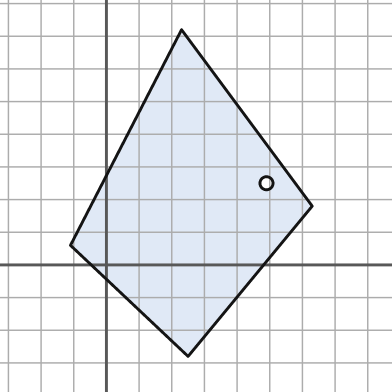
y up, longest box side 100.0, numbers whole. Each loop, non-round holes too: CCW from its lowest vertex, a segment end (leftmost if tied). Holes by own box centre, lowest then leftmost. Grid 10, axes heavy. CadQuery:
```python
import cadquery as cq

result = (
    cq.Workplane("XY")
    .moveTo(25.0, -28.0)
    .lineTo(63.0, 18.0)
    .lineTo(23.0, 72.0)
    .lineTo(-11.0, 6.0)
    .close()
    .moveTo(49.0, 25.0)
    .circle(2.0)
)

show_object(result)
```